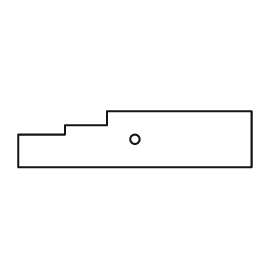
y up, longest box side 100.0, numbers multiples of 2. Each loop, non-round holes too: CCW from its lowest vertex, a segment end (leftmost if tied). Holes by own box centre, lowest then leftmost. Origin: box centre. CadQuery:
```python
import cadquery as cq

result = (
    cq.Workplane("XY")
    .moveTo(-50.0, -12.0)
    .lineTo(50.0, -12.0)
    .lineTo(50.0, 12.0)
    .lineTo(-12.0, 12.0)
    .lineTo(-12.0, 6.0)
    .lineTo(-30.0, 6.0)
    .lineTo(-30.0, 2.0)
    .lineTo(-50.0, 2.0)
    .close()
    .moveTo(0.0, 0.0)
    .circle(2.0)
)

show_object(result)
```